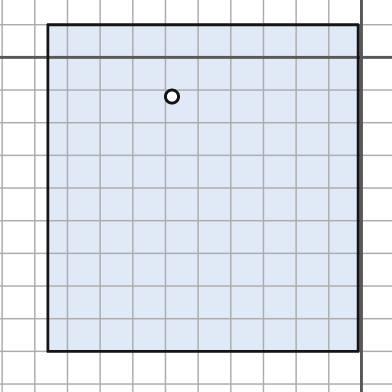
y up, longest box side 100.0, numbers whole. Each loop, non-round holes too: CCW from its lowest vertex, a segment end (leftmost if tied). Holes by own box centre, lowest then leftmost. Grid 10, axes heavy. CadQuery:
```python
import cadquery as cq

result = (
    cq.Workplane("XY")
    .moveTo(-96.0, -90.0)
    .lineTo(-1.0, -90.0)
    .lineTo(-1.0, 10.0)
    .lineTo(-96.0, 10.0)
    .close()
    .moveTo(-58.0, -12.0)
    .circle(2.0)
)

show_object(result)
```